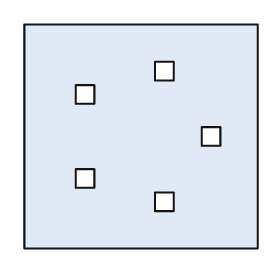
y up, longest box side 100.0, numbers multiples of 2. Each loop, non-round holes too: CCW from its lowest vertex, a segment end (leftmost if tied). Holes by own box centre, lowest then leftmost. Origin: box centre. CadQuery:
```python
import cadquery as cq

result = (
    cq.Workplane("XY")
    .moveTo(-50.0, -48.0)
    .lineTo(50.0, -48.0)
    .lineTo(50.0, 48.0)
    .lineTo(-50.0, 48.0)
    .close()
    .moveTo(6.0, -32.0)
    .lineTo(14.0, -32.0)
    .lineTo(14.0, -24.0)
    .lineTo(6.0, -24.0)
    .close()
    .moveTo(-28.0, -22.0)
    .lineTo(-20.0, -22.0)
    .lineTo(-20.0, -14.0)
    .lineTo(-28.0, -14.0)
    .close()
    .moveTo(26.0, -4.0)
    .lineTo(34.0, -4.0)
    .lineTo(34.0, 4.0)
    .lineTo(26.0, 4.0)
    .close()
    .moveTo(-28.0, 14.0)
    .lineTo(-20.0, 14.0)
    .lineTo(-20.0, 22.0)
    .lineTo(-28.0, 22.0)
    .close()
    .moveTo(6.0, 24.0)
    .lineTo(14.0, 24.0)
    .lineTo(14.0, 32.0)
    .lineTo(6.0, 32.0)
    .close()
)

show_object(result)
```